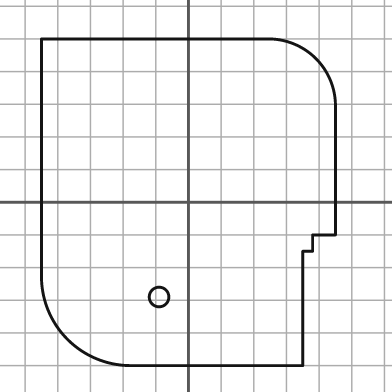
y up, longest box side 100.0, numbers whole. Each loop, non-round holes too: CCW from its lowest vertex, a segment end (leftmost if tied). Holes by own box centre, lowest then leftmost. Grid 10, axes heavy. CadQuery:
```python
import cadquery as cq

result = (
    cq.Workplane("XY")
    .moveTo(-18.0, -50.0)
    .lineTo(35.0, -50.0)
    .lineTo(35.0, -15.0)
    .lineTo(38.0, -15.0)
    .lineTo(38.0, -10.0)
    .lineTo(45.0, -10.0)
    .lineTo(45.0, 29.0)
    .threePointArc((39.0, 44.0), (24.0, 50.0))
    .lineTo(-45.0, 50.0)
    .lineTo(-45.0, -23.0)
    .threePointArc((-37.0, -42.0), (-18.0, -50.0))
    .close()
    .moveTo(-9.0, -29.0)
    .circle(3.0)
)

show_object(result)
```